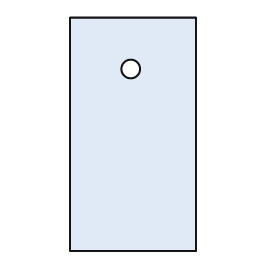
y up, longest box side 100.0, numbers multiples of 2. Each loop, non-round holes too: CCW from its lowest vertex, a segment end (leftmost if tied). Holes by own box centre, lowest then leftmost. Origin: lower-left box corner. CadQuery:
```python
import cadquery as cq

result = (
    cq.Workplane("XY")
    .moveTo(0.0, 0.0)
    .lineTo(54.0, 0.0)
    .lineTo(54.0, 100.0)
    .lineTo(0.0, 100.0)
    .close()
    .moveTo(26.0, 78.0)
    .circle(4.0)
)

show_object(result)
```